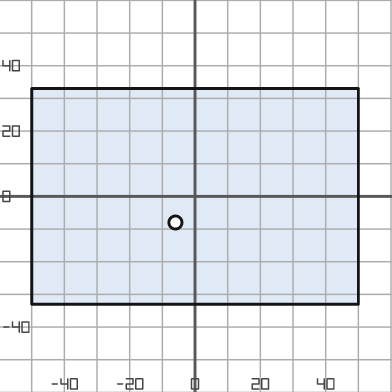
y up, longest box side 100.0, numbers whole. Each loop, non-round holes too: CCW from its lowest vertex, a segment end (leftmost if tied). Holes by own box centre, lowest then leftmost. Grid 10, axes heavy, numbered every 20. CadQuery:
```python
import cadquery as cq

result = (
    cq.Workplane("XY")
    .moveTo(-50.0, -33.0)
    .lineTo(50.0, -33.0)
    .lineTo(50.0, 33.0)
    .lineTo(-50.0, 33.0)
    .close()
    .moveTo(-6.0, -8.0)
    .circle(2.0)
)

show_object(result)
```